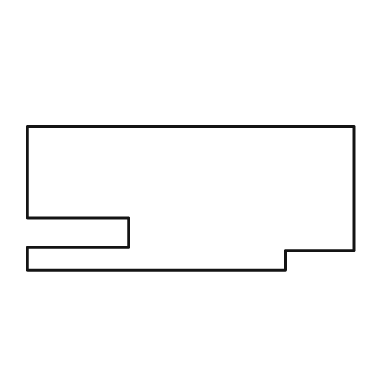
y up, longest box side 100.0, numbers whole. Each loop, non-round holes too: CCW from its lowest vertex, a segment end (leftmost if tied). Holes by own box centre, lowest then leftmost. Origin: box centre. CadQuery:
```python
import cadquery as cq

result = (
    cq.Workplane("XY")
    .moveTo(-50.0, -22.0)
    .lineTo(29.0, -22.0)
    .lineTo(29.0, -16.0)
    .lineTo(50.0, -16.0)
    .lineTo(50.0, 22.0)
    .lineTo(-50.0, 22.0)
    .lineTo(-50.0, -6.0)
    .lineTo(-19.0, -6.0)
    .lineTo(-19.0, -15.0)
    .lineTo(-50.0, -15.0)
    .close()
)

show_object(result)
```